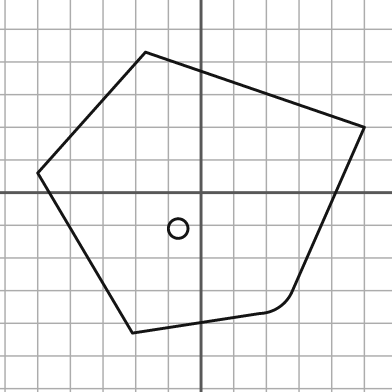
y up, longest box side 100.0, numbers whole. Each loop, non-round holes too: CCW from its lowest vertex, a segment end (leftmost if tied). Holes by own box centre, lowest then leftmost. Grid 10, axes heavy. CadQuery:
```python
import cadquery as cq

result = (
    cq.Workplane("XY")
    .moveTo(-21.0, -43.0)
    .lineTo(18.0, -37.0)
    .threePointArc((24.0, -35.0), (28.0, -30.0))
    .lineTo(50.0, 20.0)
    .lineTo(-17.0, 43.0)
    .lineTo(-50.0, 6.0)
    .close()
    .moveTo(-7.0, -11.0)
    .circle(3.0)
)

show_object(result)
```